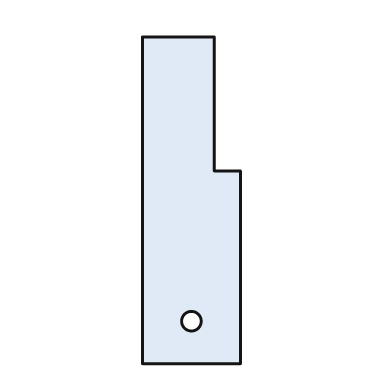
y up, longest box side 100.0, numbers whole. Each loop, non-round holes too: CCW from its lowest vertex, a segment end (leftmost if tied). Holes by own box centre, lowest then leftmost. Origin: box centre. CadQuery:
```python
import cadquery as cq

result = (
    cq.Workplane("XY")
    .moveTo(-15.0, -50.0)
    .lineTo(15.0, -50.0)
    .lineTo(15.0, 9.0)
    .lineTo(7.0, 9.0)
    .lineTo(7.0, 50.0)
    .lineTo(-15.0, 50.0)
    .close()
    .moveTo(0.0, -37.0)
    .circle(3.0)
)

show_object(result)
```